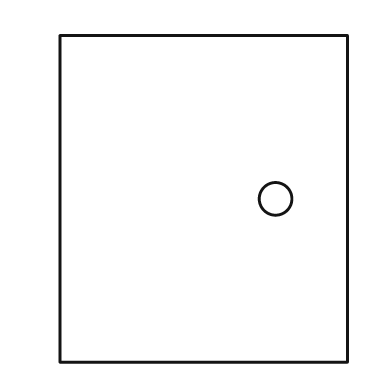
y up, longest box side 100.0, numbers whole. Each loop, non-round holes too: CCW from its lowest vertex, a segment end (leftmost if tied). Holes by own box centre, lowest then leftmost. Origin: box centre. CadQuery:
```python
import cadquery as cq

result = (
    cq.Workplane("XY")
    .moveTo(-44.0, -50.0)
    .lineTo(44.0, -50.0)
    .lineTo(44.0, 50.0)
    .lineTo(-44.0, 50.0)
    .close()
    .moveTo(22.0, 0.0)
    .circle(5.0)
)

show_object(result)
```